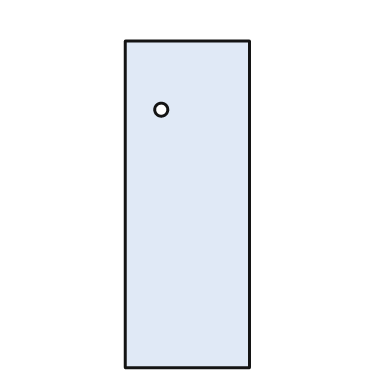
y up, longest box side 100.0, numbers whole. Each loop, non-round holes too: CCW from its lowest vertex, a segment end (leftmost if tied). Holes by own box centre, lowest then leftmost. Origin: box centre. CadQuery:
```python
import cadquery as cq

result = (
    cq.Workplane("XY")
    .moveTo(-19.0, -50.0)
    .lineTo(19.0, -50.0)
    .lineTo(19.0, 50.0)
    .lineTo(-19.0, 50.0)
    .close()
    .moveTo(-8.0, 29.0)
    .circle(2.0)
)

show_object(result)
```